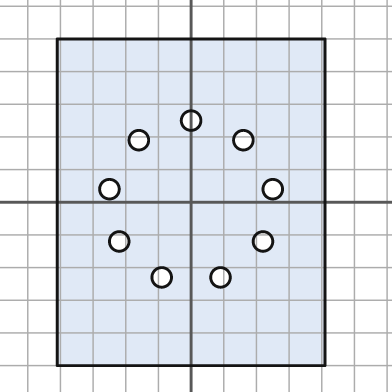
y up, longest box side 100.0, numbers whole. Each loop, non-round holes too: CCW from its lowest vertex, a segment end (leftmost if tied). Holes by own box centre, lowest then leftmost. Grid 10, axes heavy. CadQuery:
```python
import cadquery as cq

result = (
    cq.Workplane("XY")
    .moveTo(-41.0, -50.0)
    .lineTo(41.0, -50.0)
    .lineTo(41.0, 50.0)
    .lineTo(-41.0, 50.0)
    .close()
    .moveTo(-9.0, -23.0)
    .circle(3.0)
    .moveTo(9.0, -23.0)
    .circle(3.0)
    .moveTo(-22.0, -12.0)
    .circle(3.0)
    .moveTo(22.0, -12.0)
    .circle(3.0)
    .moveTo(-25.0, 4.0)
    .circle(3.0)
    .moveTo(25.0, 4.0)
    .circle(3.0)
    .moveTo(-16.0, 19.0)
    .circle(3.0)
    .moveTo(16.0, 19.0)
    .circle(3.0)
    .moveTo(0.0, 25.0)
    .circle(3.0)
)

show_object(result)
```